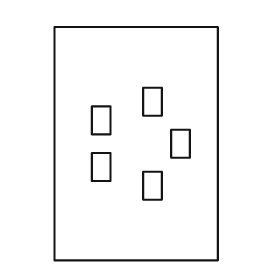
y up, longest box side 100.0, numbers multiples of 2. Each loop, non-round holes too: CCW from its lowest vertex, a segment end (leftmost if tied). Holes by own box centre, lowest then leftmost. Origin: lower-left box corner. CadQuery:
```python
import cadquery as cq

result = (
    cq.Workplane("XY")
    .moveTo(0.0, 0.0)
    .lineTo(70.0, 0.0)
    .lineTo(70.0, 100.0)
    .lineTo(0.0, 100.0)
    .close()
    .moveTo(38.0, 26.0)
    .lineTo(46.0, 26.0)
    .lineTo(46.0, 38.0)
    .lineTo(38.0, 38.0)
    .close()
    .moveTo(16.0, 34.0)
    .lineTo(24.0, 34.0)
    .lineTo(24.0, 46.0)
    .lineTo(16.0, 46.0)
    .close()
    .moveTo(50.0, 44.0)
    .lineTo(58.0, 44.0)
    .lineTo(58.0, 56.0)
    .lineTo(50.0, 56.0)
    .close()
    .moveTo(16.0, 54.0)
    .lineTo(24.0, 54.0)
    .lineTo(24.0, 66.0)
    .lineTo(16.0, 66.0)
    .close()
    .moveTo(38.0, 62.0)
    .lineTo(46.0, 62.0)
    .lineTo(46.0, 74.0)
    .lineTo(38.0, 74.0)
    .close()
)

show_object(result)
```